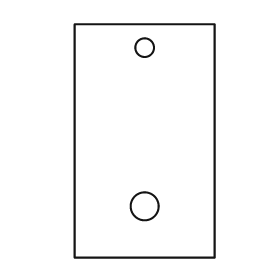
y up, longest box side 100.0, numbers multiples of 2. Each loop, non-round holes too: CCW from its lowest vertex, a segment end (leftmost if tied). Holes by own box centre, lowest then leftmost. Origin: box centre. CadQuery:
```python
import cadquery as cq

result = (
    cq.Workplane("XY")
    .moveTo(-30.0, -50.0)
    .lineTo(30.0, -50.0)
    .lineTo(30.0, 50.0)
    .lineTo(-30.0, 50.0)
    .close()
    .moveTo(0.0, -28.0)
    .circle(6.0)
    .moveTo(0.0, 40.0)
    .circle(4.0)
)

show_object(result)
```